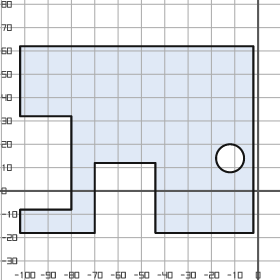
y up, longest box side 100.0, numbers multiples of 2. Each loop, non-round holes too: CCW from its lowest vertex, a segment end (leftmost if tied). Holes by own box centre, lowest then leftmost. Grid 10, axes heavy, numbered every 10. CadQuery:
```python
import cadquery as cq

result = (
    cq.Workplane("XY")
    .moveTo(-102.0, -18.0)
    .lineTo(-70.0, -18.0)
    .lineTo(-70.0, 12.0)
    .lineTo(-44.0, 12.0)
    .lineTo(-44.0, -18.0)
    .lineTo(-2.0, -18.0)
    .lineTo(-2.0, 62.0)
    .lineTo(-102.0, 62.0)
    .lineTo(-102.0, 32.0)
    .lineTo(-80.0, 32.0)
    .lineTo(-80.0, -8.0)
    .lineTo(-102.0, -8.0)
    .close()
    .moveTo(-12.0, 14.0)
    .circle(6.0)
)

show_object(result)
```